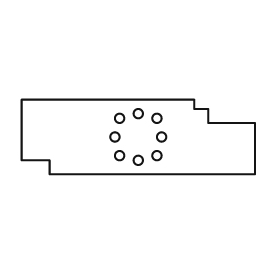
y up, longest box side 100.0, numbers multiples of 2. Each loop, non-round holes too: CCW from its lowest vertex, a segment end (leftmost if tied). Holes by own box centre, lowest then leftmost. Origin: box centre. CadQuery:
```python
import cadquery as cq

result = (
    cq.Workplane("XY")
    .moveTo(-38.0, -16.0)
    .lineTo(50.0, -16.0)
    .lineTo(50.0, 6.0)
    .lineTo(30.0, 6.0)
    .lineTo(30.0, 12.0)
    .lineTo(24.0, 12.0)
    .lineTo(24.0, 16.0)
    .lineTo(-50.0, 16.0)
    .lineTo(-50.0, -10.0)
    .lineTo(-38.0, -10.0)
    .close()
    .moveTo(0.0, -10.0)
    .circle(2.0)
    .moveTo(-8.0, -8.0)
    .circle(2.0)
    .moveTo(8.0, -8.0)
    .circle(2.0)
    .moveTo(-10.0, 0.0)
    .circle(2.0)
    .moveTo(10.0, 0.0)
    .circle(2.0)
    .moveTo(-8.0, 8.0)
    .circle(2.0)
    .moveTo(8.0, 8.0)
    .circle(2.0)
    .moveTo(0.0, 10.0)
    .circle(2.0)
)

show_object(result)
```